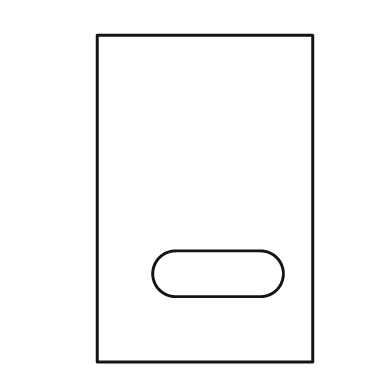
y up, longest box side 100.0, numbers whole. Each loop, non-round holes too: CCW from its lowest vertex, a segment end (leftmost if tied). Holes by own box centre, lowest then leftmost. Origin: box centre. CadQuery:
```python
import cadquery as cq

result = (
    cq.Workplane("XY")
    .moveTo(-33.0, -50.0)
    .lineTo(33.0, -50.0)
    .lineTo(33.0, 50.0)
    .lineTo(-33.0, 50.0)
    .close()
    .moveTo(-9.0, -30.0)
    .lineTo(17.0, -30.0)
    .threePointArc((24.0, -23.0), (17.0, -16.0))
    .lineTo(-9.0, -16.0)
    .threePointArc((-16.0, -23.0), (-9.0, -30.0))
    .close()
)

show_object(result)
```